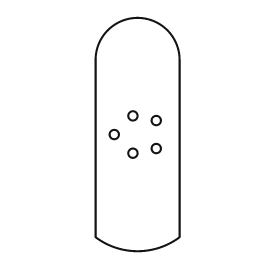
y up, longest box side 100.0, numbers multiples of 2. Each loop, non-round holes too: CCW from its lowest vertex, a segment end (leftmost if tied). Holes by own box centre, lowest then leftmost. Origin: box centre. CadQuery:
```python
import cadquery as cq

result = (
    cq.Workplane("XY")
    .moveTo(-18.0, -44.0)
    .threePointArc((0.0, -50.0), (18.0, -44.0))
    .lineTo(18.0, 32.0)
    .threePointArc((0.0, 50.0), (-18.0, 32.0))
    .close()
    .moveTo(-2.0, -8.0)
    .circle(2.0)
    .moveTo(8.0, -6.0)
    .circle(2.0)
    .moveTo(-10.0, 0.0)
    .circle(2.0)
    .moveTo(8.0, 6.0)
    .circle(2.0)
    .moveTo(-2.0, 8.0)
    .circle(2.0)
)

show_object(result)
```